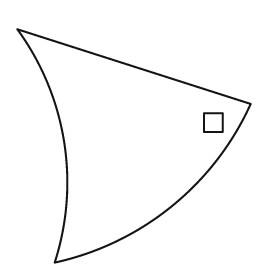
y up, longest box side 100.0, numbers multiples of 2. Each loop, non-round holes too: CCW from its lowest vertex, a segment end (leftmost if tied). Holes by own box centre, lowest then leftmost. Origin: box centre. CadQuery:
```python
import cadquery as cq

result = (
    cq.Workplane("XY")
    .moveTo(-34.0, -50.0)
    .threePointArc((16.0, -26.0), (50.0, 18.0))
    .lineTo(-50.0, 50.0)
    .threePointArc((-30.0, 2.0), (-34.0, -50.0))
    .close()
    .moveTo(30.0, 6.0)
    .lineTo(38.0, 6.0)
    .lineTo(38.0, 14.0)
    .lineTo(30.0, 14.0)
    .close()
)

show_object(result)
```